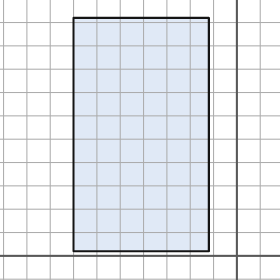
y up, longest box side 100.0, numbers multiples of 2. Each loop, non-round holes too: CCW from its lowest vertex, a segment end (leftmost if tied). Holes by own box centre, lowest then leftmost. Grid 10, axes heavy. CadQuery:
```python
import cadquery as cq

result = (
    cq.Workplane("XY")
    .moveTo(-70.0, 2.0)
    .lineTo(-12.0, 2.0)
    .lineTo(-12.0, 102.0)
    .lineTo(-70.0, 102.0)
    .close()
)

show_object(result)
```